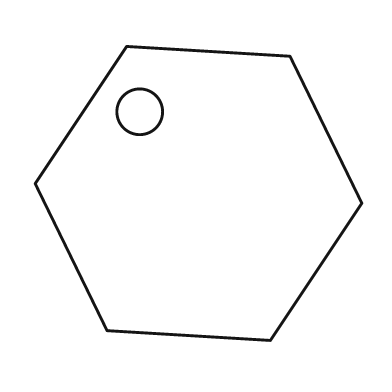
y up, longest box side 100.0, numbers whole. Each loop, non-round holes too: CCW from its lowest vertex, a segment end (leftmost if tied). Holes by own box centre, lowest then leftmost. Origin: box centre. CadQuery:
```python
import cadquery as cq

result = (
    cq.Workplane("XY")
    .moveTo(22.0, -45.0)
    .lineTo(50.0, -3.0)
    .lineTo(28.0, 42.0)
    .lineTo(-22.0, 45.0)
    .lineTo(-50.0, 3.0)
    .lineTo(-28.0, -42.0)
    .close()
    .moveTo(-18.0, 25.0)
    .circle(7.0)
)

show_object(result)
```